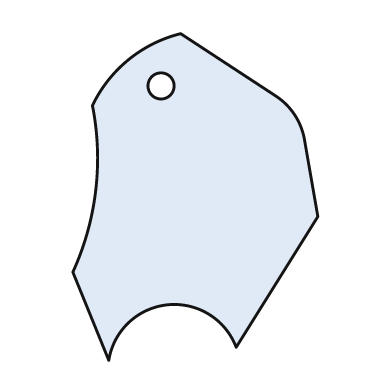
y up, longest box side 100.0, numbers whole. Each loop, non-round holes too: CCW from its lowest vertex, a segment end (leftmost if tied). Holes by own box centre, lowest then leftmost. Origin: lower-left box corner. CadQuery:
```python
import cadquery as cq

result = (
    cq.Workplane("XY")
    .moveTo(11.0, 0.0)
    .threePointArc((29.0, 17.0), (50.0, 4.0))
    .lineTo(75.0, 44.0)
    .lineTo(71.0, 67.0)
    .threePointArc((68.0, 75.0), (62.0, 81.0))
    .lineTo(33.0, 100.0)
    .threePointArc((17.0, 92.0), (6.0, 78.0))
    .threePointArc((7.0, 52.0), (0.0, 27.0))
    .close()
    .moveTo(27.0, 84.0)
    .circle(4.0)
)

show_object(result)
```